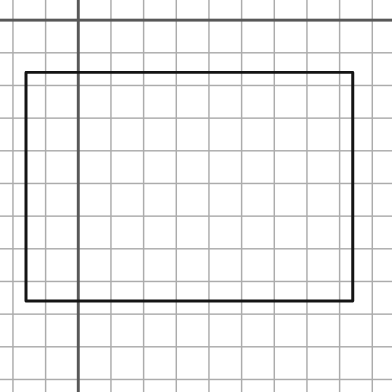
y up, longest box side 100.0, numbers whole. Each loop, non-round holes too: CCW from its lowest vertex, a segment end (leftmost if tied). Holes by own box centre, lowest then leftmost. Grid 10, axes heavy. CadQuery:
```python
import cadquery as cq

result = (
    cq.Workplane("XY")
    .moveTo(-16.0, -86.0)
    .lineTo(84.0, -86.0)
    .lineTo(84.0, -16.0)
    .lineTo(-16.0, -16.0)
    .close()
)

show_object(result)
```